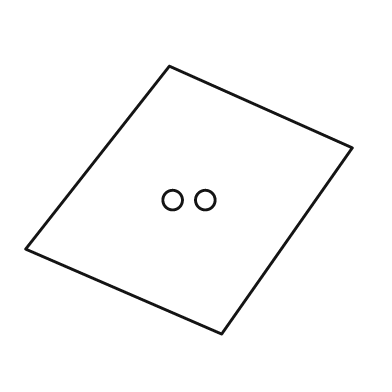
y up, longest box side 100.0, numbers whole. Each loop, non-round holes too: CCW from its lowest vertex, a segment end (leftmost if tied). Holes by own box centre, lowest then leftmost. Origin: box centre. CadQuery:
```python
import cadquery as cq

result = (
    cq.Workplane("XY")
    .moveTo(10.0, -41.0)
    .lineTo(50.0, 16.0)
    .lineTo(-6.0, 41.0)
    .lineTo(-50.0, -15.0)
    .close()
    .moveTo(-5.0, 0.0)
    .circle(3.0)
    .moveTo(5.0, 0.0)
    .circle(3.0)
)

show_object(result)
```